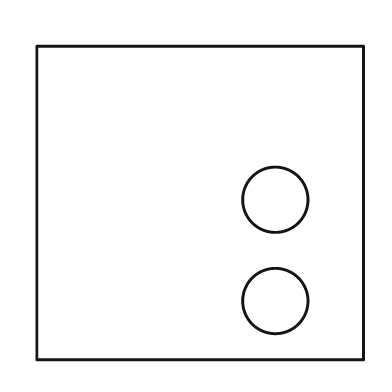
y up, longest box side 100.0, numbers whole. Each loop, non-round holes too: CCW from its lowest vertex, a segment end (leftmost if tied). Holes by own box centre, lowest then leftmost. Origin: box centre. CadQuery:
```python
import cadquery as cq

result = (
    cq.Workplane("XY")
    .moveTo(-50.0, -48.0)
    .lineTo(50.0, -48.0)
    .lineTo(50.0, 48.0)
    .lineTo(-50.0, 48.0)
    .close()
    .moveTo(23.0, -30.0)
    .circle(10.0)
    .moveTo(23.0, 1.0)
    .circle(10.0)
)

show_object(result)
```